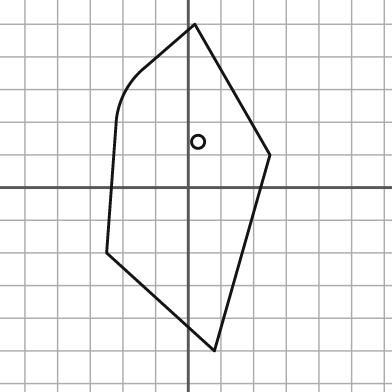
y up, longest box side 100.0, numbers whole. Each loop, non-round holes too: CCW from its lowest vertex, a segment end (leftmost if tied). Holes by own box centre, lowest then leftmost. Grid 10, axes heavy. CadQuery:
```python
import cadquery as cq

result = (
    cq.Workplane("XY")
    .moveTo(8.0, -50.0)
    .lineTo(25.0, 10.0)
    .lineTo(2.0, 50.0)
    .lineTo(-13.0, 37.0)
    .threePointArc((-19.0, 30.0), (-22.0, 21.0))
    .lineTo(-25.0, -20.0)
    .close()
    .moveTo(3.0, 14.0)
    .circle(2.0)
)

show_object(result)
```